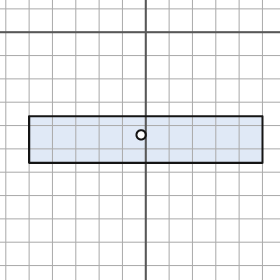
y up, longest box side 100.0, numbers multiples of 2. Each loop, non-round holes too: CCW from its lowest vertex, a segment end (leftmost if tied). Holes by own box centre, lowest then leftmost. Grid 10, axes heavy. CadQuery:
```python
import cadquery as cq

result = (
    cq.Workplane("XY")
    .moveTo(-50.0, -56.0)
    .lineTo(50.0, -56.0)
    .lineTo(50.0, -36.0)
    .lineTo(-50.0, -36.0)
    .close()
    .moveTo(-2.0, -44.0)
    .circle(2.0)
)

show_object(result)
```